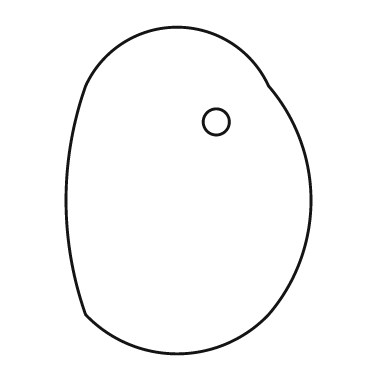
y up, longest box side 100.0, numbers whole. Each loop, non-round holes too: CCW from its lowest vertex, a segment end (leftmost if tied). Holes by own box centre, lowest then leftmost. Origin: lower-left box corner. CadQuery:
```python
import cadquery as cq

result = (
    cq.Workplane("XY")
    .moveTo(6.0, 12.0)
    .threePointArc((34.0, 0.0), (62.0, 12.0))
    .threePointArc((75.0, 47.0), (62.0, 82.0))
    .threePointArc((34.0, 100.0), (6.0, 82.0))
    .threePointArc((0.0, 47.0), (6.0, 12.0))
    .close()
    .moveTo(46.0, 71.0)
    .circle(4.0)
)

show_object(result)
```